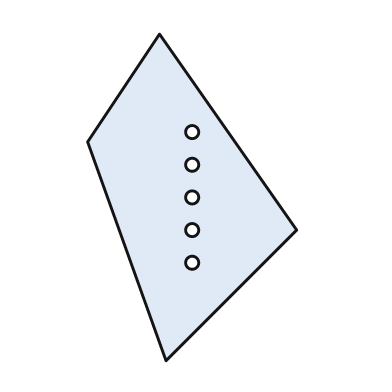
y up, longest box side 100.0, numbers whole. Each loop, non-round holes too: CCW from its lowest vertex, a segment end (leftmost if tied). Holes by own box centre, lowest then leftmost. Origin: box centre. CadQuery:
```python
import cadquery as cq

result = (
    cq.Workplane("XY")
    .moveTo(-8.0, -50.0)
    .lineTo(32.0, -10.0)
    .lineTo(-10.0, 50.0)
    .lineTo(-32.0, 17.0)
    .close()
    .moveTo(0.0, -20.0)
    .circle(2.0)
    .moveTo(0.0, -10.0)
    .circle(2.0)
    .moveTo(0.0, 0.0)
    .circle(2.0)
    .moveTo(0.0, 10.0)
    .circle(2.0)
    .moveTo(0.0, 20.0)
    .circle(2.0)
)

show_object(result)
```